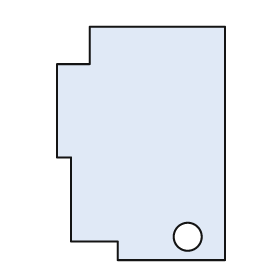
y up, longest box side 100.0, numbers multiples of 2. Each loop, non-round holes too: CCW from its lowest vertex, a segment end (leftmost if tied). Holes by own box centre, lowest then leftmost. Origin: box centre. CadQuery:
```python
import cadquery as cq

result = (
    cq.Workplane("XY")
    .moveTo(-10.0, -50.0)
    .lineTo(36.0, -50.0)
    .lineTo(36.0, 50.0)
    .lineTo(-22.0, 50.0)
    .lineTo(-22.0, 34.0)
    .lineTo(-36.0, 34.0)
    .lineTo(-36.0, -6.0)
    .lineTo(-30.0, -6.0)
    .lineTo(-30.0, -42.0)
    .lineTo(-10.0, -42.0)
    .close()
    .moveTo(20.0, -40.0)
    .circle(6.0)
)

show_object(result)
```